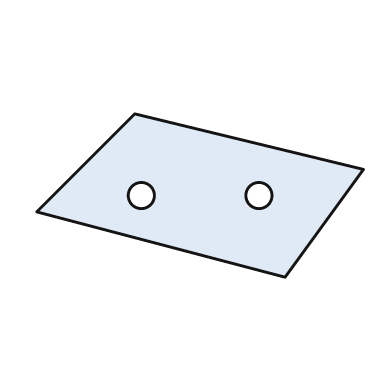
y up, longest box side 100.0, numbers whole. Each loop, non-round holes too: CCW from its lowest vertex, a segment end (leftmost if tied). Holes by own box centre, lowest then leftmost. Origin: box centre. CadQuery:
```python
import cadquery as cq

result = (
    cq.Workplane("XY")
    .moveTo(26.0, -25.0)
    .lineTo(50.0, 8.0)
    .lineTo(-20.0, 25.0)
    .lineTo(-50.0, -5.0)
    .close()
    .moveTo(-18.0, 0.0)
    .circle(4.0)
    .moveTo(18.0, 0.0)
    .circle(4.0)
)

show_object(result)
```